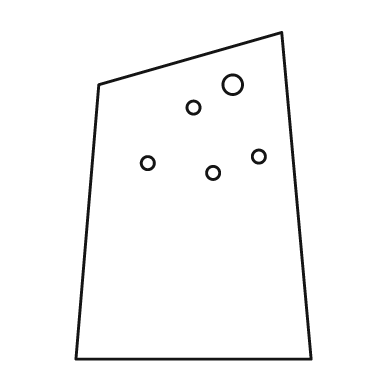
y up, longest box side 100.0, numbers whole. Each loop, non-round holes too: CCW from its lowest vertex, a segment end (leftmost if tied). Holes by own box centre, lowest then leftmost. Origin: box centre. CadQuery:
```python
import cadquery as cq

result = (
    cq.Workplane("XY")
    .moveTo(-36.0, -50.0)
    .lineTo(36.0, -50.0)
    .lineTo(27.0, 50.0)
    .lineTo(-29.0, 34.0)
    .close()
    .moveTo(6.0, 7.0)
    .circle(2.0)
    .moveTo(-14.0, 10.0)
    .circle(2.0)
    .moveTo(20.0, 12.0)
    .circle(2.0)
    .moveTo(0.0, 27.0)
    .circle(2.0)
    .moveTo(12.0, 34.0)
    .circle(3.0)
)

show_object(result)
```